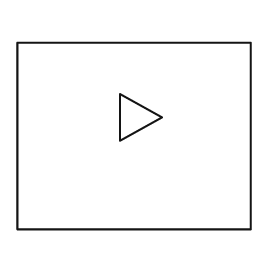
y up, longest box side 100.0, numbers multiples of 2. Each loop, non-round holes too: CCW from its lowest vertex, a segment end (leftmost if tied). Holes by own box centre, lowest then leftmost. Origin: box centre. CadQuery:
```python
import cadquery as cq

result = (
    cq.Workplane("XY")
    .moveTo(-50.0, -40.0)
    .lineTo(50.0, -40.0)
    .lineTo(50.0, 40.0)
    .lineTo(-50.0, 40.0)
    .close()
    .moveTo(-6.0, -2.0)
    .lineTo(12.0, 8.0)
    .lineTo(-6.0, 18.0)
    .close()
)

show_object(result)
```